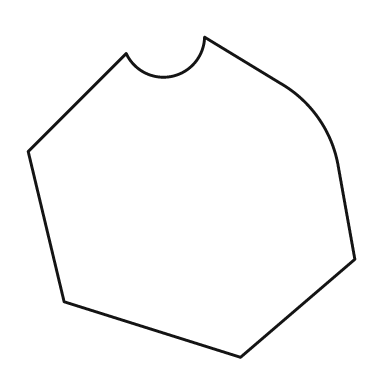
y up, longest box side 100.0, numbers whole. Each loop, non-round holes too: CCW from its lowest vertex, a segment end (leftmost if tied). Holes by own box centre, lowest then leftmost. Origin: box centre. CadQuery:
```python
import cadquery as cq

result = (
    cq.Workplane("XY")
    .moveTo(15.0, -49.0)
    .lineTo(50.0, -19.0)
    .lineTo(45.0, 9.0)
    .threePointArc((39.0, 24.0), (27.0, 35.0))
    .lineTo(4.0, 49.0)
    .threePointArc((-6.0, 37.0), (-20.0, 44.0))
    .lineTo(-50.0, 14.0)
    .lineTo(-39.0, -32.0)
    .close()
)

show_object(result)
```